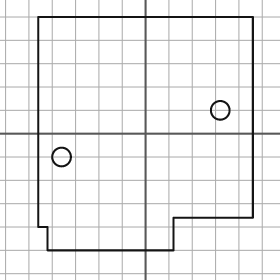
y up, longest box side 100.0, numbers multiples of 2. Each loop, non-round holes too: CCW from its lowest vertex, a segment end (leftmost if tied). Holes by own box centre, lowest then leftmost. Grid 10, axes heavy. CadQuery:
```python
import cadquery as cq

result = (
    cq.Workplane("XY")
    .moveTo(-42.0, -50.0)
    .lineTo(12.0, -50.0)
    .lineTo(12.0, -36.0)
    .lineTo(46.0, -36.0)
    .lineTo(46.0, 50.0)
    .lineTo(-46.0, 50.0)
    .lineTo(-46.0, -40.0)
    .lineTo(-42.0, -40.0)
    .close()
    .moveTo(-36.0, -10.0)
    .circle(4.0)
    .moveTo(32.0, 10.0)
    .circle(4.0)
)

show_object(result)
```